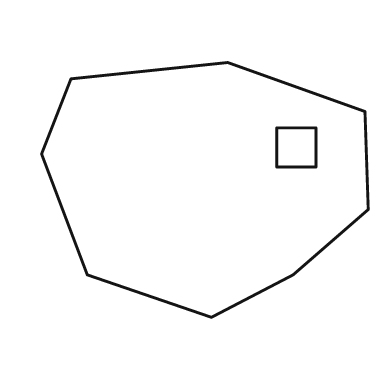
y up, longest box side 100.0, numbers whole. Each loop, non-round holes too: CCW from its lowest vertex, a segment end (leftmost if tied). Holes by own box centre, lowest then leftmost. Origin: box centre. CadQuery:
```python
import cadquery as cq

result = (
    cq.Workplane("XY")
    .moveTo(2.0, -39.0)
    .lineTo(27.0, -26.0)
    .lineTo(50.0, -6.0)
    .lineTo(49.0, 24.0)
    .lineTo(7.0, 39.0)
    .lineTo(-41.0, 34.0)
    .lineTo(-50.0, 11.0)
    .lineTo(-36.0, -26.0)
    .close()
    .moveTo(22.0, 7.0)
    .lineTo(34.0, 7.0)
    .lineTo(34.0, 19.0)
    .lineTo(22.0, 19.0)
    .close()
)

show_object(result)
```